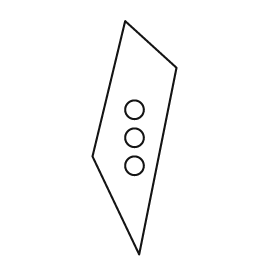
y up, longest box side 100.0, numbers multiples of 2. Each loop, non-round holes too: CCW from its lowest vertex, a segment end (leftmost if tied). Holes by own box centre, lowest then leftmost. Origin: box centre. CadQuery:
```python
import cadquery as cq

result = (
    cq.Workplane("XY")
    .moveTo(2.0, -50.0)
    .lineTo(18.0, 30.0)
    .lineTo(-4.0, 50.0)
    .lineTo(-18.0, -8.0)
    .close()
    .moveTo(0.0, -12.0)
    .circle(4.0)
    .moveTo(0.0, 0.0)
    .circle(4.0)
    .moveTo(0.0, 12.0)
    .circle(4.0)
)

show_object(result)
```